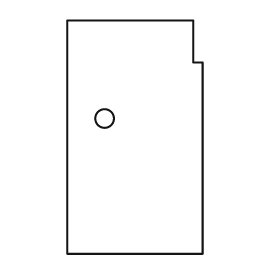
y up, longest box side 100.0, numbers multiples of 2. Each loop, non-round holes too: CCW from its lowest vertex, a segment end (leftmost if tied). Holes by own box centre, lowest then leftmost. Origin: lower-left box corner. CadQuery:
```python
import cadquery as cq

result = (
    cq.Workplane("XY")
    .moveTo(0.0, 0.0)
    .lineTo(58.0, 0.0)
    .lineTo(58.0, 82.0)
    .lineTo(54.0, 82.0)
    .lineTo(54.0, 100.0)
    .lineTo(0.0, 100.0)
    .close()
    .moveTo(16.0, 58.0)
    .circle(4.0)
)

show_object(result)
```